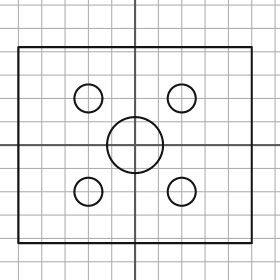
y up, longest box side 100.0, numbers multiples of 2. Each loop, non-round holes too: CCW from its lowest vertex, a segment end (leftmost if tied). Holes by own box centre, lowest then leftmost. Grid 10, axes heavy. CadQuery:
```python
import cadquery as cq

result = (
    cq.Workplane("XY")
    .moveTo(-50.0, -42.0)
    .lineTo(50.0, -42.0)
    .lineTo(50.0, 42.0)
    .lineTo(-50.0, 42.0)
    .close()
    .moveTo(-20.0, -20.0)
    .circle(6.0)
    .moveTo(20.0, -20.0)
    .circle(6.0)
    .moveTo(0.0, 0.0)
    .circle(12.0)
    .moveTo(-20.0, 20.0)
    .circle(6.0)
    .moveTo(20.0, 20.0)
    .circle(6.0)
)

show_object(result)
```